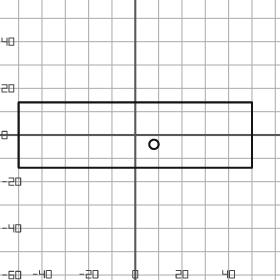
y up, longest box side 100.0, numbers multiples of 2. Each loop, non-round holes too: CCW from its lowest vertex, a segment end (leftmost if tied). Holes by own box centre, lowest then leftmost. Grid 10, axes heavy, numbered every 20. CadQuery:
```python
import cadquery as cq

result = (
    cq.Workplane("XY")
    .moveTo(-50.0, -14.0)
    .lineTo(50.0, -14.0)
    .lineTo(50.0, 14.0)
    .lineTo(-50.0, 14.0)
    .close()
    .moveTo(8.0, -4.0)
    .circle(2.0)
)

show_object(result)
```